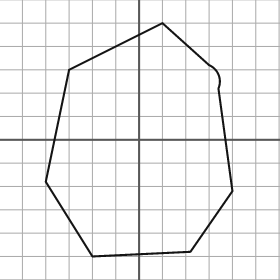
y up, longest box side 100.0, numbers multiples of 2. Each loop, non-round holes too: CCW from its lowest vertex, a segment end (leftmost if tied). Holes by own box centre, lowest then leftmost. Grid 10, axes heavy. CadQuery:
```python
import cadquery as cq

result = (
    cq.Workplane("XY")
    .moveTo(-20.0, -50.0)
    .lineTo(22.0, -48.0)
    .lineTo(40.0, -22.0)
    .lineTo(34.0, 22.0)
    .threePointArc((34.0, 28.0), (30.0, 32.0))
    .lineTo(10.0, 50.0)
    .lineTo(-30.0, 30.0)
    .lineTo(-40.0, -18.0)
    .close()
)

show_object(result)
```